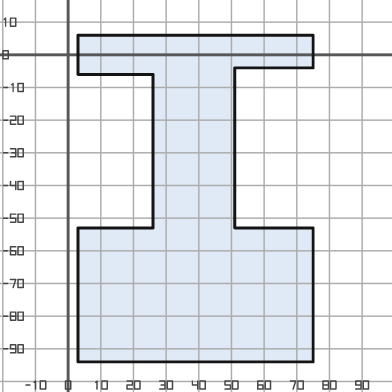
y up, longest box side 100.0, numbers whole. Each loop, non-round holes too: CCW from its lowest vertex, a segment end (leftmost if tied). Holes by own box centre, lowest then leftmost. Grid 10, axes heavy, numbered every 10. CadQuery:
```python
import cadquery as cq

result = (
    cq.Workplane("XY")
    .moveTo(3.0, -94.0)
    .lineTo(75.0, -94.0)
    .lineTo(75.0, -53.0)
    .lineTo(51.0, -53.0)
    .lineTo(51.0, -4.0)
    .lineTo(75.0, -4.0)
    .lineTo(75.0, 6.0)
    .lineTo(3.0, 6.0)
    .lineTo(3.0, -6.0)
    .lineTo(26.0, -6.0)
    .lineTo(26.0, -53.0)
    .lineTo(3.0, -53.0)
    .close()
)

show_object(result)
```